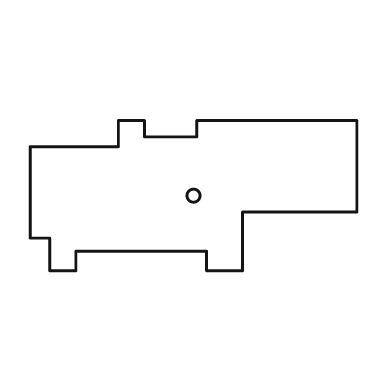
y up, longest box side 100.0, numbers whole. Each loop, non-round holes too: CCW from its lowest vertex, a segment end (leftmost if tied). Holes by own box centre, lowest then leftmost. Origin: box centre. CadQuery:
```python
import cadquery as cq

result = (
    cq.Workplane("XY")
    .moveTo(-44.0, -23.0)
    .lineTo(-36.0, -23.0)
    .lineTo(-36.0, -17.0)
    .lineTo(4.0, -17.0)
    .lineTo(4.0, -23.0)
    .lineTo(15.0, -23.0)
    .lineTo(15.0, -5.0)
    .lineTo(50.0, -5.0)
    .lineTo(50.0, 23.0)
    .lineTo(1.0, 23.0)
    .lineTo(1.0, 18.0)
    .lineTo(-15.0, 18.0)
    .lineTo(-15.0, 23.0)
    .lineTo(-23.0, 23.0)
    .lineTo(-23.0, 15.0)
    .lineTo(-50.0, 15.0)
    .lineTo(-50.0, -13.0)
    .lineTo(-44.0, -13.0)
    .close()
    .moveTo(0.0, 0.0)
    .circle(2.0)
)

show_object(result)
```